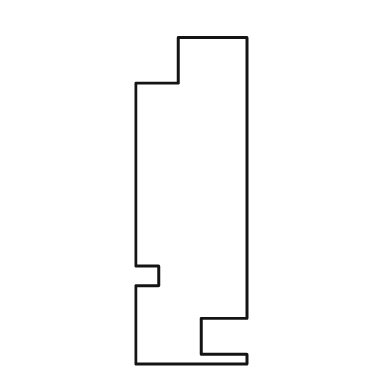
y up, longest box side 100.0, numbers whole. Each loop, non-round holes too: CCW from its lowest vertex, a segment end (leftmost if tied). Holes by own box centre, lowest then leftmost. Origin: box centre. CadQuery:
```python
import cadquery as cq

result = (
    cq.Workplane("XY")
    .moveTo(-17.0, -50.0)
    .lineTo(17.0, -50.0)
    .lineTo(17.0, -47.0)
    .lineTo(3.0, -47.0)
    .lineTo(3.0, -36.0)
    .lineTo(17.0, -36.0)
    .lineTo(17.0, 50.0)
    .lineTo(-4.0, 50.0)
    .lineTo(-4.0, 36.0)
    .lineTo(-17.0, 36.0)
    .lineTo(-17.0, -20.0)
    .lineTo(-10.0, -20.0)
    .lineTo(-10.0, -26.0)
    .lineTo(-17.0, -26.0)
    .close()
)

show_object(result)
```